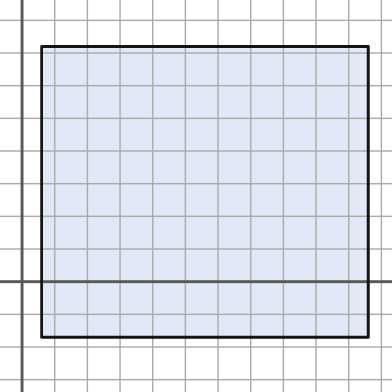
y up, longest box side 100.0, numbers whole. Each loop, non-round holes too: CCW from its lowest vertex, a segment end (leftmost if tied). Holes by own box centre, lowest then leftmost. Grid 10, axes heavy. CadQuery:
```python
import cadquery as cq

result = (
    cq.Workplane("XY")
    .moveTo(6.0, -17.0)
    .lineTo(106.0, -17.0)
    .lineTo(106.0, 72.0)
    .lineTo(6.0, 72.0)
    .close()
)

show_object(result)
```